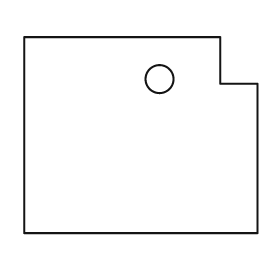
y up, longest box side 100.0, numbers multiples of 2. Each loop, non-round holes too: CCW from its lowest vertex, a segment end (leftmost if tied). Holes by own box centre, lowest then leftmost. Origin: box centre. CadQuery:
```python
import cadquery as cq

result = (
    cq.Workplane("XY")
    .moveTo(-50.0, -42.0)
    .lineTo(50.0, -42.0)
    .lineTo(50.0, 22.0)
    .lineTo(34.0, 22.0)
    .lineTo(34.0, 42.0)
    .lineTo(-50.0, 42.0)
    .close()
    .moveTo(8.0, 24.0)
    .circle(6.0)
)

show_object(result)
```